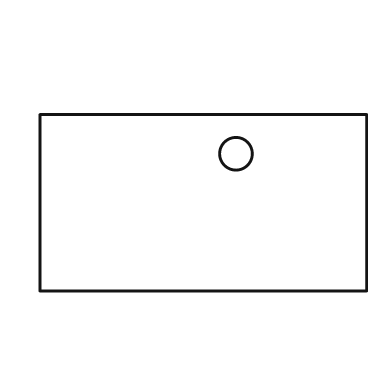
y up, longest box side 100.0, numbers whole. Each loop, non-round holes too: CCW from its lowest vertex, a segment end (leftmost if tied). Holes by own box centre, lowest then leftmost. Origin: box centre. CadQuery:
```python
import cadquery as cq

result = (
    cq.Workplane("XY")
    .moveTo(-50.0, -27.0)
    .lineTo(50.0, -27.0)
    .lineTo(50.0, 27.0)
    .lineTo(-50.0, 27.0)
    .close()
    .moveTo(10.0, 15.0)
    .circle(5.0)
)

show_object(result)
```